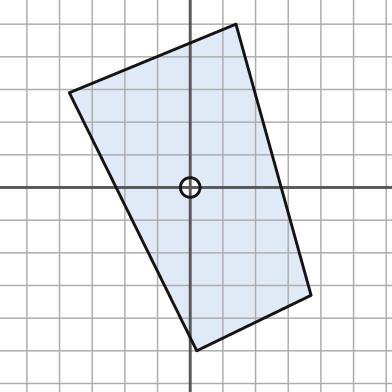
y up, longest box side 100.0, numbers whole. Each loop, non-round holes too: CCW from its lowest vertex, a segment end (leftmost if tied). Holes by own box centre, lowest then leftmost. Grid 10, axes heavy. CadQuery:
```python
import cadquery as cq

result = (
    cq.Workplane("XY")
    .moveTo(2.0, -50.0)
    .lineTo(37.0, -33.0)
    .lineTo(14.0, 50.0)
    .lineTo(-37.0, 29.0)
    .close()
    .moveTo(0.0, 0.0)
    .circle(3.0)
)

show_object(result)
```